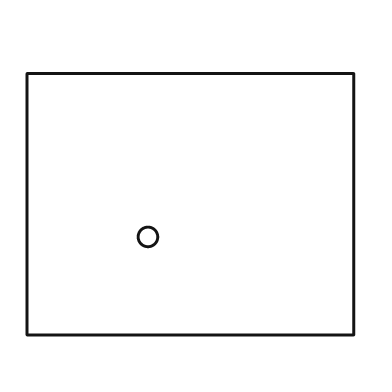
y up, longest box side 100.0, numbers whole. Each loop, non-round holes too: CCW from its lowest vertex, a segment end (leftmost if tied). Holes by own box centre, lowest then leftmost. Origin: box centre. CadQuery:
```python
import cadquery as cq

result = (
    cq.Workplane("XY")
    .moveTo(-50.0, -40.0)
    .lineTo(50.0, -40.0)
    .lineTo(50.0, 40.0)
    .lineTo(-50.0, 40.0)
    .close()
    .moveTo(-13.0, -10.0)
    .circle(3.0)
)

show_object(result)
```